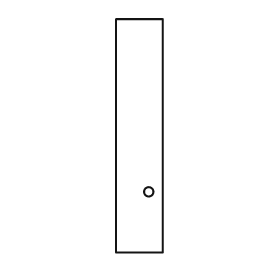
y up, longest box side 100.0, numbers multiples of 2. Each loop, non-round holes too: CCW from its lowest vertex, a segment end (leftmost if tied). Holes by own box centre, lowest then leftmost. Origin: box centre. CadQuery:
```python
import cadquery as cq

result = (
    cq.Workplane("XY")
    .moveTo(-10.0, -50.0)
    .lineTo(10.0, -50.0)
    .lineTo(10.0, 50.0)
    .lineTo(-10.0, 50.0)
    .close()
    .moveTo(4.0, -24.0)
    .circle(2.0)
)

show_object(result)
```